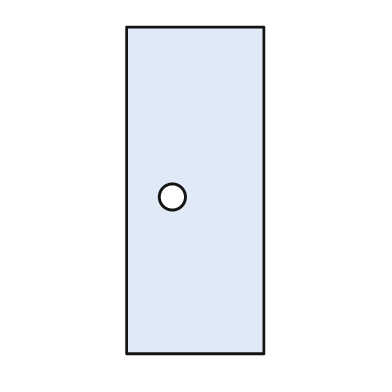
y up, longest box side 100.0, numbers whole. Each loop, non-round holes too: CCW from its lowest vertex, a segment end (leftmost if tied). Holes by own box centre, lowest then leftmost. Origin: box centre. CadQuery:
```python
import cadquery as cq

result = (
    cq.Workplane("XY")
    .moveTo(-21.0, -50.0)
    .lineTo(21.0, -50.0)
    .lineTo(21.0, 50.0)
    .lineTo(-21.0, 50.0)
    .close()
    .moveTo(-7.0, -2.0)
    .circle(4.0)
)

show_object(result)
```